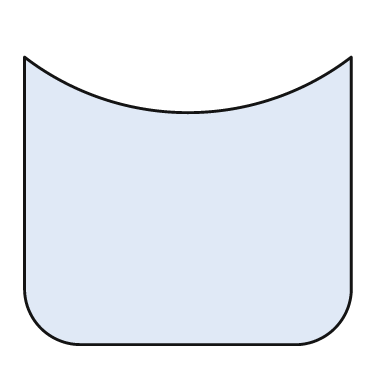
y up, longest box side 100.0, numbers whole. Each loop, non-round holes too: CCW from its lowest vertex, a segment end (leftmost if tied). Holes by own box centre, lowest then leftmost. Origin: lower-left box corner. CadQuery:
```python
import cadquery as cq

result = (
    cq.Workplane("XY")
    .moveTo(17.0, 0.0)
    .lineTo(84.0, 0.0)
    .threePointArc((95.0, 5.0), (100.0, 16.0))
    .lineTo(100.0, 88.0)
    .threePointArc((50.0, 71.0), (0.0, 88.0))
    .lineTo(0.0, 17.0)
    .threePointArc((5.0, 5.0), (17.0, 0.0))
    .close()
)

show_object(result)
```